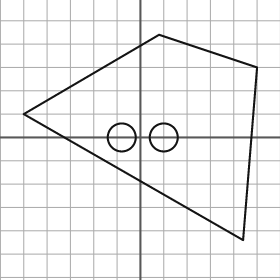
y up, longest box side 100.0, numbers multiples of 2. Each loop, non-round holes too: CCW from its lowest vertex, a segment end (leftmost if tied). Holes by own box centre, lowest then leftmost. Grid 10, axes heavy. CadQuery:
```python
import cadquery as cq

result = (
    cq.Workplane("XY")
    .moveTo(44.0, -44.0)
    .lineTo(50.0, 30.0)
    .lineTo(8.0, 44.0)
    .lineTo(-50.0, 10.0)
    .close()
    .moveTo(-8.0, 0.0)
    .circle(6.0)
    .moveTo(10.0, 0.0)
    .circle(6.0)
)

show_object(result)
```